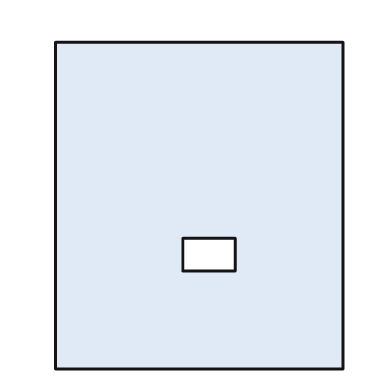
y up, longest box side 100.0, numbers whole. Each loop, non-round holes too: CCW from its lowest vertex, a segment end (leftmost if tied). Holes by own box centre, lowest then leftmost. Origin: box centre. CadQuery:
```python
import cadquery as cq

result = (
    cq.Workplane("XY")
    .moveTo(-44.0, -50.0)
    .lineTo(44.0, -50.0)
    .lineTo(44.0, 50.0)
    .lineTo(-44.0, 50.0)
    .close()
    .moveTo(-5.0, -20.0)
    .lineTo(11.0, -20.0)
    .lineTo(11.0, -10.0)
    .lineTo(-5.0, -10.0)
    .close()
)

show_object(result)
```